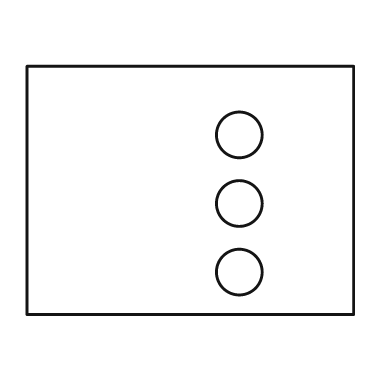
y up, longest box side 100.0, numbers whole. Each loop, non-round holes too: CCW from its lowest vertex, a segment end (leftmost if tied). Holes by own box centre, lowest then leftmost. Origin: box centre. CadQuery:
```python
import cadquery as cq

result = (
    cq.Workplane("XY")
    .moveTo(-50.0, -38.0)
    .lineTo(50.0, -38.0)
    .lineTo(50.0, 38.0)
    .lineTo(-50.0, 38.0)
    .close()
    .moveTo(15.0, -25.0)
    .circle(7.0)
    .moveTo(15.0, -4.0)
    .circle(7.0)
    .moveTo(15.0, 17.0)
    .circle(7.0)
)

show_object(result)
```